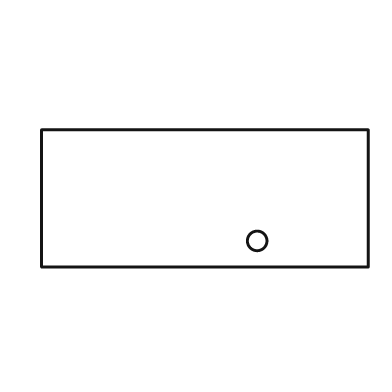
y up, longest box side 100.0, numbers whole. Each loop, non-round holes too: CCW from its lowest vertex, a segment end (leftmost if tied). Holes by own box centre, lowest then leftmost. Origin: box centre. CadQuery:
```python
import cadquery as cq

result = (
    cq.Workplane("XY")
    .moveTo(-50.0, -21.0)
    .lineTo(50.0, -21.0)
    .lineTo(50.0, 21.0)
    .lineTo(-50.0, 21.0)
    .close()
    .moveTo(16.0, -13.0)
    .circle(3.0)
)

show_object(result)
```